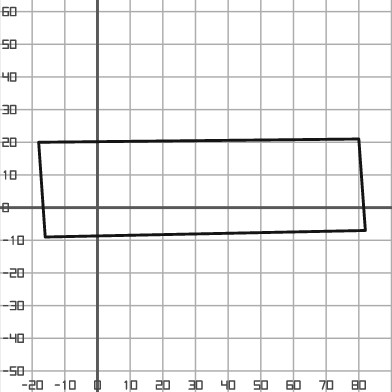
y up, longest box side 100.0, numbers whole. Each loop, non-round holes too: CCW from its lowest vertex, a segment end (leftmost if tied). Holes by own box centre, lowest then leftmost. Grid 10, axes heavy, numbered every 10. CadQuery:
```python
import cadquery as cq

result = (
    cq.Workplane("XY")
    .moveTo(-16.0, -9.0)
    .lineTo(82.0, -7.0)
    .lineTo(80.0, 21.0)
    .lineTo(-18.0, 20.0)
    .close()
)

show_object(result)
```